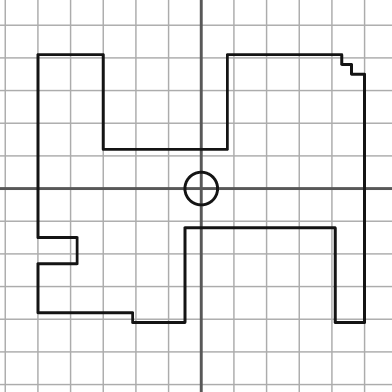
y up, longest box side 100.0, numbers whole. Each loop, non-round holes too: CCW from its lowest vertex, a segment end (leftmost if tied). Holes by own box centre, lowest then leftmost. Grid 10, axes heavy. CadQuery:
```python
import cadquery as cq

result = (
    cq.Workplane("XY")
    .moveTo(-21.0, -41.0)
    .lineTo(-5.0, -41.0)
    .lineTo(-5.0, -12.0)
    .lineTo(41.0, -12.0)
    .lineTo(41.0, -41.0)
    .lineTo(50.0, -41.0)
    .lineTo(50.0, 35.0)
    .lineTo(46.0, 35.0)
    .lineTo(46.0, 38.0)
    .lineTo(43.0, 38.0)
    .lineTo(43.0, 41.0)
    .lineTo(8.0, 41.0)
    .lineTo(8.0, 12.0)
    .lineTo(-30.0, 12.0)
    .lineTo(-30.0, 41.0)
    .lineTo(-50.0, 41.0)
    .lineTo(-50.0, -15.0)
    .lineTo(-38.0, -15.0)
    .lineTo(-38.0, -23.0)
    .lineTo(-50.0, -23.0)
    .lineTo(-50.0, -38.0)
    .lineTo(-21.0, -38.0)
    .close()
    .moveTo(0.0, 0.0)
    .circle(5.0)
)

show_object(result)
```